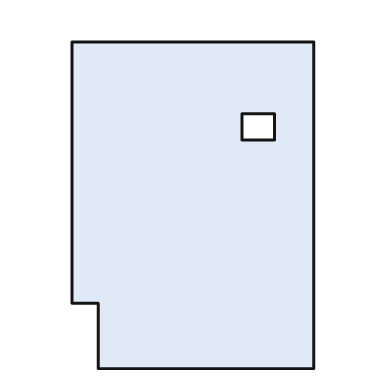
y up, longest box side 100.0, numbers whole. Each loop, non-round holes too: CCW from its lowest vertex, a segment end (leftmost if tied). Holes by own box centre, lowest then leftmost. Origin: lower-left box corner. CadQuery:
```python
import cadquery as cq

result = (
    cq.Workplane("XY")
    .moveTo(8.0, 0.0)
    .lineTo(74.0, 0.0)
    .lineTo(74.0, 100.0)
    .lineTo(0.0, 100.0)
    .lineTo(0.0, 20.0)
    .lineTo(8.0, 20.0)
    .close()
    .moveTo(52.0, 70.0)
    .lineTo(62.0, 70.0)
    .lineTo(62.0, 78.0)
    .lineTo(52.0, 78.0)
    .close()
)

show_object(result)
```